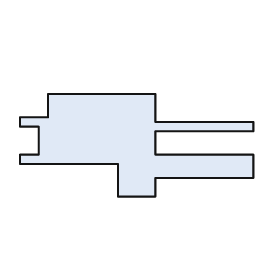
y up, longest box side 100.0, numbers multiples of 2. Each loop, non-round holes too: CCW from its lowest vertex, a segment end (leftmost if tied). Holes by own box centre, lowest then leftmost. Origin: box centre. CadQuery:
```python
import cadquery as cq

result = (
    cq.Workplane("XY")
    .moveTo(-8.0, -22.0)
    .lineTo(8.0, -22.0)
    .lineTo(8.0, -14.0)
    .lineTo(50.0, -14.0)
    .lineTo(50.0, -4.0)
    .lineTo(8.0, -4.0)
    .lineTo(8.0, 6.0)
    .lineTo(50.0, 6.0)
    .lineTo(50.0, 10.0)
    .lineTo(8.0, 10.0)
    .lineTo(8.0, 22.0)
    .lineTo(-38.0, 22.0)
    .lineTo(-38.0, 12.0)
    .lineTo(-50.0, 12.0)
    .lineTo(-50.0, 8.0)
    .lineTo(-42.0, 8.0)
    .lineTo(-42.0, -4.0)
    .lineTo(-50.0, -4.0)
    .lineTo(-50.0, -8.0)
    .lineTo(-8.0, -8.0)
    .close()
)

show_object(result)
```